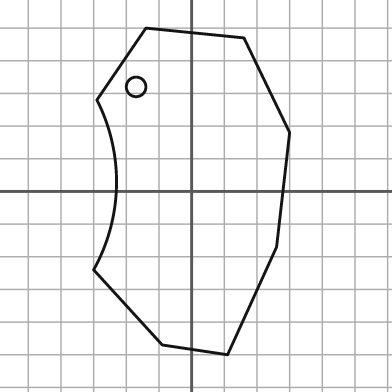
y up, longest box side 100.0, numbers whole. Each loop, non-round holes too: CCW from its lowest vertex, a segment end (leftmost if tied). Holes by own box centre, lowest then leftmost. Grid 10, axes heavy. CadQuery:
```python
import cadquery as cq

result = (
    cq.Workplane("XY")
    .moveTo(11.0, -50.0)
    .lineTo(26.0, -17.0)
    .lineTo(30.0, 18.0)
    .lineTo(16.0, 47.0)
    .lineTo(-14.0, 50.0)
    .lineTo(-29.0, 28.0)
    .threePointArc((-23.0, 2.0), (-30.0, -24.0))
    .lineTo(-9.0, -47.0)
    .close()
    .moveTo(-17.0, 32.0)
    .circle(3.0)
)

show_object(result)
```